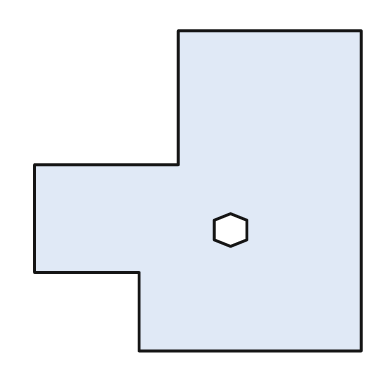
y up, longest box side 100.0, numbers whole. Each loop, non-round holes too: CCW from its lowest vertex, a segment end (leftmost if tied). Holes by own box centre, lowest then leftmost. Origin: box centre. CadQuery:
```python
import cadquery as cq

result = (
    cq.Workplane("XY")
    .moveTo(-18.0, -49.0)
    .lineTo(50.0, -49.0)
    .lineTo(50.0, 49.0)
    .lineTo(-6.0, 49.0)
    .lineTo(-6.0, 8.0)
    .lineTo(-50.0, 8.0)
    .lineTo(-50.0, -25.0)
    .lineTo(-18.0, -25.0)
    .close()
    .moveTo(10.0, -17.0)
    .lineTo(15.0, -15.0)
    .lineTo(15.0, -9.0)
    .lineTo(10.0, -7.0)
    .lineTo(5.0, -9.0)
    .lineTo(5.0, -15.0)
    .close()
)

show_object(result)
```